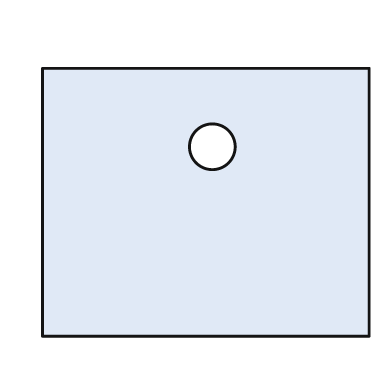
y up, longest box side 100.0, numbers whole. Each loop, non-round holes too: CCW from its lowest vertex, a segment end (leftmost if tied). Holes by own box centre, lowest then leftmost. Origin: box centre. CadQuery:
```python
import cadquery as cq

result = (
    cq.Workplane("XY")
    .moveTo(-50.0, -41.0)
    .lineTo(50.0, -41.0)
    .lineTo(50.0, 41.0)
    .lineTo(-50.0, 41.0)
    .close()
    .moveTo(2.0, 17.0)
    .circle(7.0)
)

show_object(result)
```